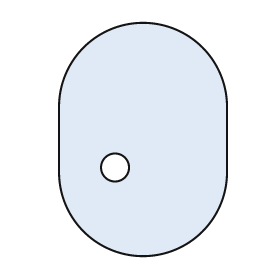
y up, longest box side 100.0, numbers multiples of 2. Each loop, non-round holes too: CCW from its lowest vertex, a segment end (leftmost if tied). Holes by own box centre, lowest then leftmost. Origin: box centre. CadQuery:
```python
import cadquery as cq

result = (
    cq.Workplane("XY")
    .moveTo(-36.0, -14.0)
    .threePointArc((0.0, -50.0), (36.0, -14.0))
    .lineTo(36.0, 14.0)
    .threePointArc((0.0, 50.0), (-36.0, 14.0))
    .close()
    .moveTo(-12.0, -12.0)
    .circle(6.0)
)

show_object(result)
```